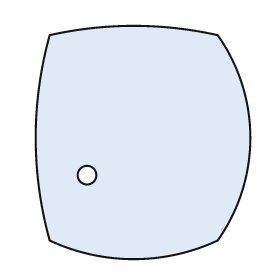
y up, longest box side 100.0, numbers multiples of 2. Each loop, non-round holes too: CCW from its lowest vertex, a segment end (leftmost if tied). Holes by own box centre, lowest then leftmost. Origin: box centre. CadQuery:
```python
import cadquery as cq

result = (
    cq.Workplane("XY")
    .moveTo(-40.0, -42.0)
    .threePointArc((-4.0, -50.0), (32.0, -42.0))
    .threePointArc((46.0, 2.0), (32.0, 46.0))
    .threePointArc((-4.0, 50.0), (-40.0, 46.0))
    .threePointArc((-46.0, 2.0), (-40.0, -42.0))
    .close()
    .moveTo(-24.0, -14.0)
    .circle(4.0)
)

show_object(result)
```